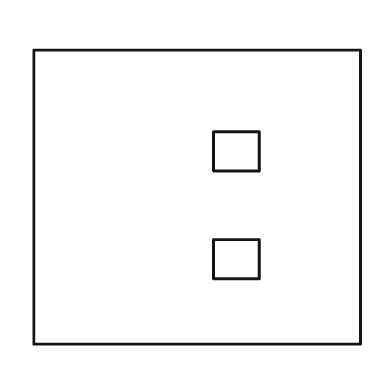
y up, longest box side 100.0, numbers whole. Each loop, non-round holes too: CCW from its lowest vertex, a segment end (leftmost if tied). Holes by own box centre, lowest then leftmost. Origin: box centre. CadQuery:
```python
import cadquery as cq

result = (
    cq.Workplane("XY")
    .moveTo(-50.0, -45.0)
    .lineTo(50.0, -45.0)
    .lineTo(50.0, 45.0)
    .lineTo(-50.0, 45.0)
    .close()
    .moveTo(5.0, -25.0)
    .lineTo(19.0, -25.0)
    .lineTo(19.0, -13.0)
    .lineTo(5.0, -13.0)
    .close()
    .moveTo(5.0, 8.0)
    .lineTo(19.0, 8.0)
    .lineTo(19.0, 20.0)
    .lineTo(5.0, 20.0)
    .close()
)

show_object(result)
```